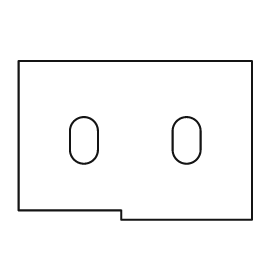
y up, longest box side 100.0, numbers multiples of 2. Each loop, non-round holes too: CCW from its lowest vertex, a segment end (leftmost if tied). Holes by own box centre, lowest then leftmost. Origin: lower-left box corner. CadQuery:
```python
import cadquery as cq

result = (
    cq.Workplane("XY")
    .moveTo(44.0, 0.0)
    .lineTo(100.0, 0.0)
    .lineTo(100.0, 68.0)
    .lineTo(0.0, 68.0)
    .lineTo(0.0, 4.0)
    .lineTo(44.0, 4.0)
    .close()
    .moveTo(22.0, 30.0)
    .threePointArc((28.0, 24.0), (34.0, 30.0))
    .lineTo(34.0, 38.0)
    .threePointArc((28.0, 44.0), (22.0, 38.0))
    .close()
    .moveTo(66.0, 30.0)
    .threePointArc((72.0, 24.0), (78.0, 30.0))
    .lineTo(78.0, 38.0)
    .threePointArc((72.0, 44.0), (66.0, 38.0))
    .close()
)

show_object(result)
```